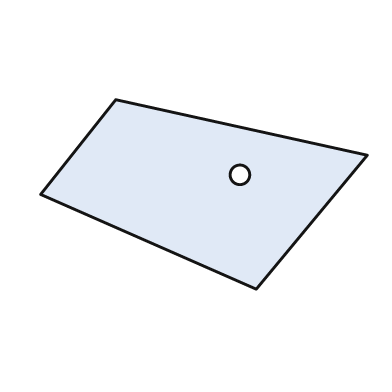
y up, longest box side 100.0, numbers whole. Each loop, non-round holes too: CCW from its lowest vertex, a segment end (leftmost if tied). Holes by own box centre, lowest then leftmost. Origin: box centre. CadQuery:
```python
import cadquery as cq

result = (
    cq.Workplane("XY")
    .moveTo(16.0, -29.0)
    .lineTo(50.0, 12.0)
    .lineTo(-27.0, 29.0)
    .lineTo(-50.0, 0.0)
    .close()
    .moveTo(11.0, 6.0)
    .circle(3.0)
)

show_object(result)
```